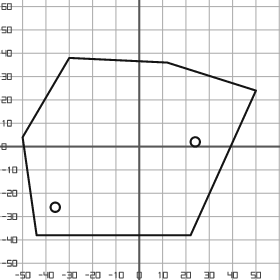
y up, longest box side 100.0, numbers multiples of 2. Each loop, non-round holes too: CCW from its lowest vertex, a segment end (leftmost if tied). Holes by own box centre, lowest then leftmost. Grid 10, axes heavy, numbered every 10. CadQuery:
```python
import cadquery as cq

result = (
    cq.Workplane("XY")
    .moveTo(-44.0, -38.0)
    .lineTo(22.0, -38.0)
    .lineTo(50.0, 24.0)
    .lineTo(12.0, 36.0)
    .lineTo(-30.0, 38.0)
    .lineTo(-50.0, 4.0)
    .close()
    .moveTo(-36.0, -26.0)
    .circle(2.0)
    .moveTo(24.0, 2.0)
    .circle(2.0)
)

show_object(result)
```